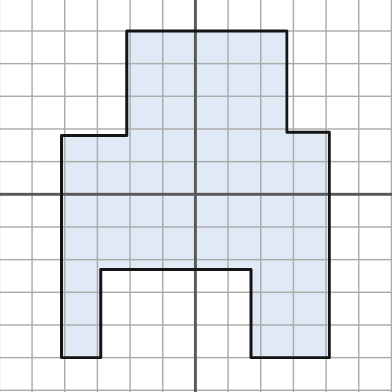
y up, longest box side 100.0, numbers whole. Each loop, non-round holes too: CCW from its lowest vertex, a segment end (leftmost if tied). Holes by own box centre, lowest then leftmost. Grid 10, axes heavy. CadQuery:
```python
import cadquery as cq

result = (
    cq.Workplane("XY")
    .moveTo(-41.0, -50.0)
    .lineTo(-29.0, -50.0)
    .lineTo(-29.0, -23.0)
    .lineTo(17.0, -23.0)
    .lineTo(17.0, -50.0)
    .lineTo(41.0, -50.0)
    .lineTo(41.0, 19.0)
    .lineTo(28.0, 19.0)
    .lineTo(28.0, 50.0)
    .lineTo(-21.0, 50.0)
    .lineTo(-21.0, 18.0)
    .lineTo(-41.0, 18.0)
    .close()
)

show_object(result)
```